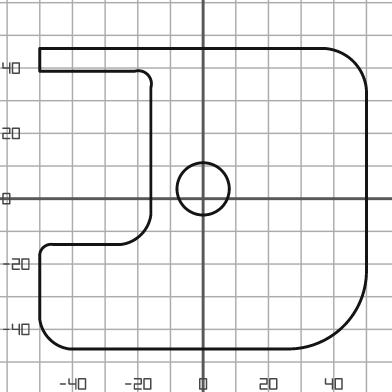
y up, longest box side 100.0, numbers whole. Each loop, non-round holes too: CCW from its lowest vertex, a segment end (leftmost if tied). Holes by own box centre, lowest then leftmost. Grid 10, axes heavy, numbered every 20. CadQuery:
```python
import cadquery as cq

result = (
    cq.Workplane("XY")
    .moveTo(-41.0, -46.0)
    .lineTo(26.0, -46.0)
    .threePointArc((43.0, -39.0), (50.0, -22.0))
    .lineTo(50.0, 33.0)
    .threePointArc((46.0, 42.0), (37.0, 46.0))
    .lineTo(-50.0, 46.0)
    .lineTo(-50.0, 39.0)
    .lineTo(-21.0, 39.0)
    .threePointArc((-17.0, 38.0), (-16.0, 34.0))
    .lineTo(-16.0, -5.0)
    .threePointArc((-19.0, -11.0), (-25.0, -14.0))
    .lineTo(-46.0, -14.0)
    .threePointArc((-49.0, -15.0), (-50.0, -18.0))
    .lineTo(-50.0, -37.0)
    .threePointArc((-47.0, -43.0), (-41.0, -46.0))
    .close()
    .moveTo(0.0, 3.0)
    .circle(8.0)
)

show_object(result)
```